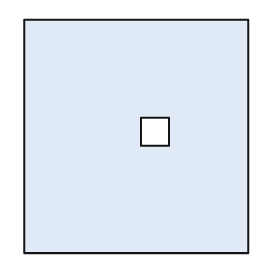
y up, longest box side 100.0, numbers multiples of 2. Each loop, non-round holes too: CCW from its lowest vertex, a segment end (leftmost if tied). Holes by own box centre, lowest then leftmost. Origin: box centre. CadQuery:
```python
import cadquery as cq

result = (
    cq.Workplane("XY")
    .moveTo(-48.0, -50.0)
    .lineTo(48.0, -50.0)
    .lineTo(48.0, 50.0)
    .lineTo(-48.0, 50.0)
    .close()
    .moveTo(2.0, -4.0)
    .lineTo(14.0, -4.0)
    .lineTo(14.0, 8.0)
    .lineTo(2.0, 8.0)
    .close()
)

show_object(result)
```